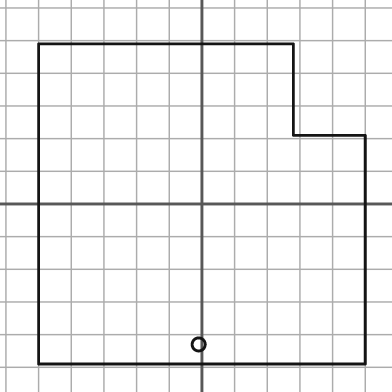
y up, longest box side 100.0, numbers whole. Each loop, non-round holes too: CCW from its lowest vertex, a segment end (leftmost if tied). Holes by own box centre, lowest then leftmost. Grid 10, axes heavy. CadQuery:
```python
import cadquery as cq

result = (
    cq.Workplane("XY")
    .moveTo(-50.0, -49.0)
    .lineTo(50.0, -49.0)
    .lineTo(50.0, 21.0)
    .lineTo(28.0, 21.0)
    .lineTo(28.0, 49.0)
    .lineTo(-50.0, 49.0)
    .close()
    .moveTo(-1.0, -43.0)
    .circle(2.0)
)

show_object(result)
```